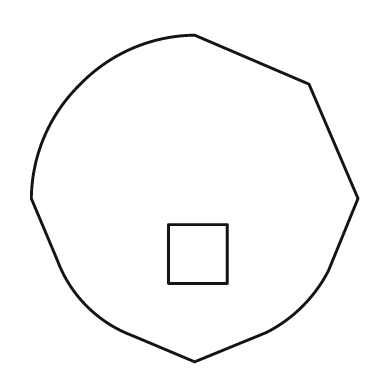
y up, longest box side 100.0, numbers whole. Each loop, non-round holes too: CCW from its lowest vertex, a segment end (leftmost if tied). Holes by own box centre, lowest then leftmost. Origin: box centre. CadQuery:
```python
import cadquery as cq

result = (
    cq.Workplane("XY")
    .moveTo(0.0, -50.0)
    .lineTo(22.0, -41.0)
    .threePointArc((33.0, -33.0), (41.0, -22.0))
    .lineTo(50.0, 0.0)
    .lineTo(35.0, 35.0)
    .lineTo(0.0, 50.0)
    .threePointArc((-19.0, 46.0), (-35.0, 35.0))
    .threePointArc((-46.0, 19.0), (-50.0, 0.0))
    .lineTo(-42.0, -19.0)
    .threePointArc((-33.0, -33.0), (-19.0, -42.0))
    .close()
    .moveTo(-8.0, -26.0)
    .lineTo(10.0, -26.0)
    .lineTo(10.0, -8.0)
    .lineTo(-8.0, -8.0)
    .close()
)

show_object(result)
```